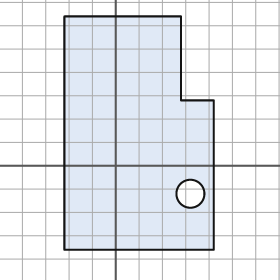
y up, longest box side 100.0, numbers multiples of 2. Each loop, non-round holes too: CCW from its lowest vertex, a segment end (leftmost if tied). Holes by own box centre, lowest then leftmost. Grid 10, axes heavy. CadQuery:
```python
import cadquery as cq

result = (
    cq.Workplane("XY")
    .moveTo(-22.0, -36.0)
    .lineTo(42.0, -36.0)
    .lineTo(42.0, 28.0)
    .lineTo(28.0, 28.0)
    .lineTo(28.0, 64.0)
    .lineTo(-22.0, 64.0)
    .close()
    .moveTo(32.0, -12.0)
    .circle(6.0)
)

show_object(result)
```